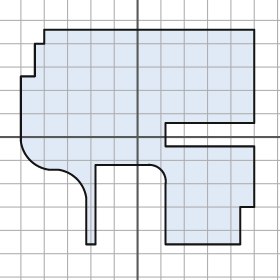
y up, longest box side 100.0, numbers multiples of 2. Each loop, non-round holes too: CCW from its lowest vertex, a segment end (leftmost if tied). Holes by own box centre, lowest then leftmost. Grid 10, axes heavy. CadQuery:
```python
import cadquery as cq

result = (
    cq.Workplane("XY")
    .moveTo(-22.0, -46.0)
    .lineTo(-18.0, -46.0)
    .lineTo(-18.0, -12.0)
    .lineTo(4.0, -12.0)
    .threePointArc((10.0, -14.0), (12.0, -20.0))
    .lineTo(12.0, -46.0)
    .lineTo(44.0, -46.0)
    .lineTo(44.0, -30.0)
    .lineTo(50.0, -30.0)
    .lineTo(50.0, -4.0)
    .lineTo(12.0, -4.0)
    .lineTo(12.0, 6.0)
    .lineTo(50.0, 6.0)
    .lineTo(50.0, 46.0)
    .lineTo(-40.0, 46.0)
    .lineTo(-40.0, 40.0)
    .lineTo(-44.0, 40.0)
    .lineTo(-44.0, 26.0)
    .lineTo(-50.0, 26.0)
    .lineTo(-50.0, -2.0)
    .threePointArc((-46.0, -10.0), (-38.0, -14.0))
    .lineTo(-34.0, -14.0)
    .threePointArc((-26.0, -18.0), (-22.0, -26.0))
    .close()
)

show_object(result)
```